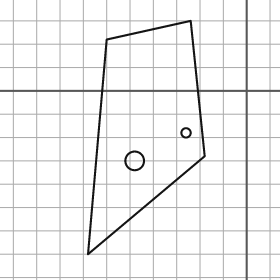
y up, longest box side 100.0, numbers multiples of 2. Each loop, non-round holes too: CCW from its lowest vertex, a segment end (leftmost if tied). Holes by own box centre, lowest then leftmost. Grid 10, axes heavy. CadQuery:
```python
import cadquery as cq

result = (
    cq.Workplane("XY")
    .moveTo(-68.0, -70.0)
    .lineTo(-18.0, -28.0)
    .lineTo(-24.0, 30.0)
    .lineTo(-60.0, 22.0)
    .close()
    .moveTo(-48.0, -30.0)
    .circle(4.0)
    .moveTo(-26.0, -18.0)
    .circle(2.0)
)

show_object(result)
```